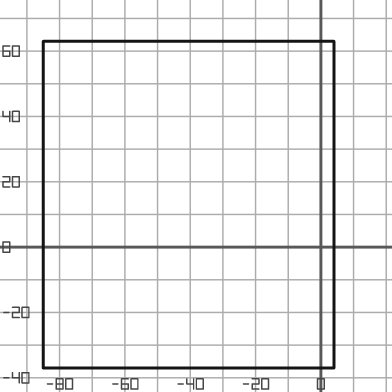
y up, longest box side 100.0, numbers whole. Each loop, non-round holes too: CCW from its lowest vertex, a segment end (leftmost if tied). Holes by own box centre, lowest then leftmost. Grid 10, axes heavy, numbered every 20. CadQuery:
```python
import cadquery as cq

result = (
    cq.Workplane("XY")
    .moveTo(-85.0, -37.0)
    .lineTo(4.0, -37.0)
    .lineTo(4.0, 63.0)
    .lineTo(-85.0, 63.0)
    .close()
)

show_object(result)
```